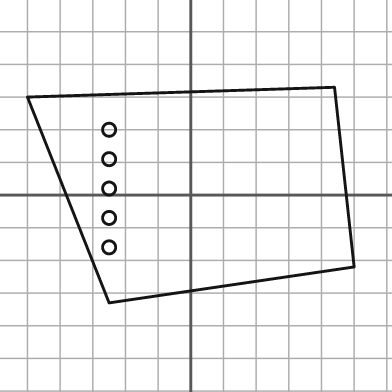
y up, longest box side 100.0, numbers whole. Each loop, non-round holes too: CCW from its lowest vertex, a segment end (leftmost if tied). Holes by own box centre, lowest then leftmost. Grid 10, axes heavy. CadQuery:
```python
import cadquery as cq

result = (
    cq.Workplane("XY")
    .moveTo(-25.0, -33.0)
    .lineTo(50.0, -22.0)
    .lineTo(44.0, 33.0)
    .lineTo(-50.0, 30.0)
    .close()
    .moveTo(-25.0, -16.0)
    .circle(2.0)
    .moveTo(-25.0, -7.0)
    .circle(2.0)
    .moveTo(-25.0, 2.0)
    .circle(2.0)
    .moveTo(-25.0, 11.0)
    .circle(2.0)
    .moveTo(-25.0, 20.0)
    .circle(2.0)
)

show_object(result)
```